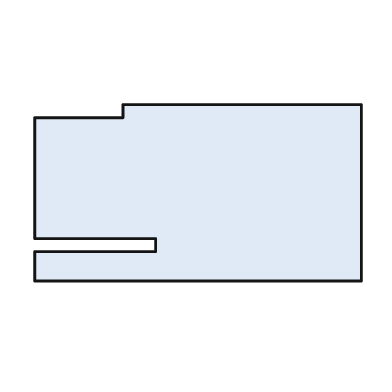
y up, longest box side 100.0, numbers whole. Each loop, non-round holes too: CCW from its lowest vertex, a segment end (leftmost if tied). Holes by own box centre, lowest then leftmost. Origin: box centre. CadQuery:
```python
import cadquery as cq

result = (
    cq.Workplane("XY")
    .moveTo(-50.0, -27.0)
    .lineTo(50.0, -27.0)
    .lineTo(50.0, 27.0)
    .lineTo(-23.0, 27.0)
    .lineTo(-23.0, 23.0)
    .lineTo(-50.0, 23.0)
    .lineTo(-50.0, -14.0)
    .lineTo(-13.0, -14.0)
    .lineTo(-13.0, -18.0)
    .lineTo(-50.0, -18.0)
    .close()
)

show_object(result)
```